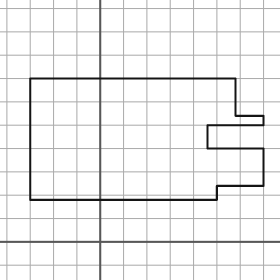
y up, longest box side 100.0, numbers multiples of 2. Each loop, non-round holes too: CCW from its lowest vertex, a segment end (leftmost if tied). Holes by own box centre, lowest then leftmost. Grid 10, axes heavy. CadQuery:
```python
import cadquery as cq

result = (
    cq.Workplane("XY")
    .moveTo(-30.0, 18.0)
    .lineTo(50.0, 18.0)
    .lineTo(50.0, 24.0)
    .lineTo(70.0, 24.0)
    .lineTo(70.0, 40.0)
    .lineTo(46.0, 40.0)
    .lineTo(46.0, 50.0)
    .lineTo(70.0, 50.0)
    .lineTo(70.0, 54.0)
    .lineTo(58.0, 54.0)
    .lineTo(58.0, 70.0)
    .lineTo(-30.0, 70.0)
    .close()
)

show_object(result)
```